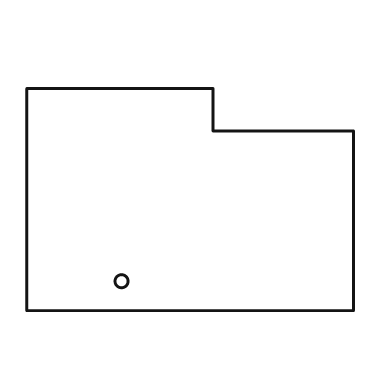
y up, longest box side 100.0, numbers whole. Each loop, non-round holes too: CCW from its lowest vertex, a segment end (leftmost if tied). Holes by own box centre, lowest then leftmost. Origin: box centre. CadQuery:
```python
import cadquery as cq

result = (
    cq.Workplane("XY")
    .moveTo(-50.0, -34.0)
    .lineTo(50.0, -34.0)
    .lineTo(50.0, 21.0)
    .lineTo(7.0, 21.0)
    .lineTo(7.0, 34.0)
    .lineTo(-50.0, 34.0)
    .close()
    .moveTo(-21.0, -25.0)
    .circle(2.0)
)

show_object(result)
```